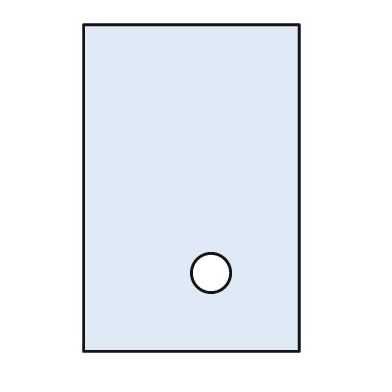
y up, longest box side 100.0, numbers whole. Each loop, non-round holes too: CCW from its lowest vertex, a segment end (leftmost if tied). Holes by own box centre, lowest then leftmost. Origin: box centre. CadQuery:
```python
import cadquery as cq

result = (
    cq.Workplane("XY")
    .moveTo(-33.0, -50.0)
    .lineTo(33.0, -50.0)
    .lineTo(33.0, 50.0)
    .lineTo(-33.0, 50.0)
    .close()
    .moveTo(6.0, -26.0)
    .circle(6.0)
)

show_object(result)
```